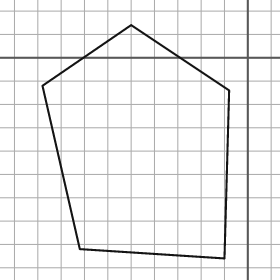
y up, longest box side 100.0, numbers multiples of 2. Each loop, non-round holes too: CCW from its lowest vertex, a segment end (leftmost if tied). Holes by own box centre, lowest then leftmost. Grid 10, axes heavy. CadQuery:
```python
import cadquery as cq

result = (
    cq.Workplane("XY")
    .moveTo(-10.0, -86.0)
    .lineTo(-8.0, -14.0)
    .lineTo(-50.0, 14.0)
    .lineTo(-88.0, -12.0)
    .lineTo(-72.0, -82.0)
    .close()
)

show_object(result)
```